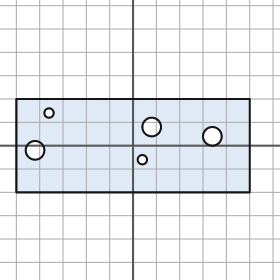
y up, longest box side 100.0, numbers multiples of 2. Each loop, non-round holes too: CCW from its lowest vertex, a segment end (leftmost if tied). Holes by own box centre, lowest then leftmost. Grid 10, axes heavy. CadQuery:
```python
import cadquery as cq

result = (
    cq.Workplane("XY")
    .moveTo(-50.0, -20.0)
    .lineTo(50.0, -20.0)
    .lineTo(50.0, 20.0)
    .lineTo(-50.0, 20.0)
    .close()
    .moveTo(4.0, -6.0)
    .circle(2.0)
    .moveTo(-42.0, -2.0)
    .circle(4.0)
    .moveTo(34.0, 4.0)
    .circle(4.0)
    .moveTo(8.0, 8.0)
    .circle(4.0)
    .moveTo(-36.0, 14.0)
    .circle(2.0)
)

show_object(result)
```